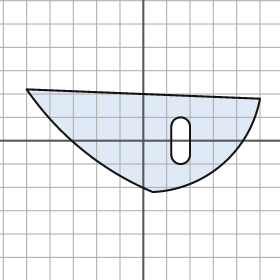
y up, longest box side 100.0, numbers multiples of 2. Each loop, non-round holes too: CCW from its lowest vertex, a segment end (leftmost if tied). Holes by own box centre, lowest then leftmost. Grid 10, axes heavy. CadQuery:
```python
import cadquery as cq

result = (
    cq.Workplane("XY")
    .moveTo(4.0, -22.0)
    .threePointArc((34.0, -10.0), (50.0, 18.0))
    .lineTo(-50.0, 22.0)
    .threePointArc((-26.0, -4.0), (4.0, -22.0))
    .close()
    .moveTo(12.0, -6.0)
    .threePointArc((16.0, -10.0), (20.0, -6.0))
    .lineTo(20.0, 6.0)
    .threePointArc((16.0, 10.0), (12.0, 6.0))
    .close()
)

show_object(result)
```